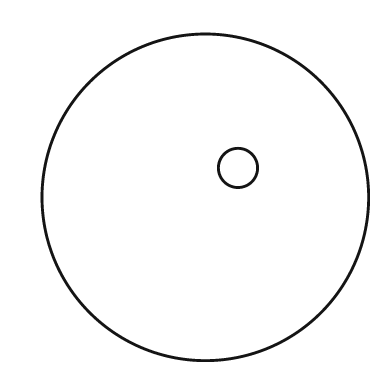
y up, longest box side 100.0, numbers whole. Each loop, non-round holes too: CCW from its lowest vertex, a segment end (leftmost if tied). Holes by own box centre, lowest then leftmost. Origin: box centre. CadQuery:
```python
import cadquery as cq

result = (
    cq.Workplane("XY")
    .moveTo(0.0, 0.0)
    .circle(50.0)
    .moveTo(10.0, 9.0)
    .circle(6.0)
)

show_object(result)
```